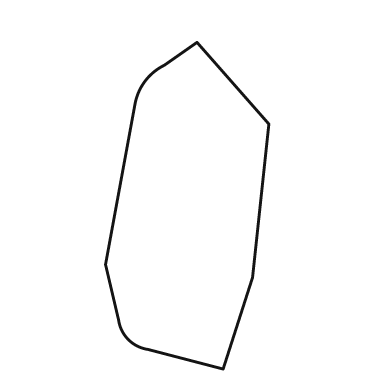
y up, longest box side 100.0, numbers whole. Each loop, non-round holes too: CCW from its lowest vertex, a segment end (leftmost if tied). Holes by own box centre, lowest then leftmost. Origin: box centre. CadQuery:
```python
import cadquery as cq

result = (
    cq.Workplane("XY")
    .moveTo(11.0, -50.0)
    .lineTo(20.0, -22.0)
    .lineTo(25.0, 25.0)
    .lineTo(3.0, 50.0)
    .lineTo(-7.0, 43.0)
    .threePointArc((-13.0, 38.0), (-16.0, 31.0))
    .lineTo(-25.0, -18.0)
    .lineTo(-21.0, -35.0)
    .threePointArc((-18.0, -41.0), (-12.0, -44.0))
    .close()
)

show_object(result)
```